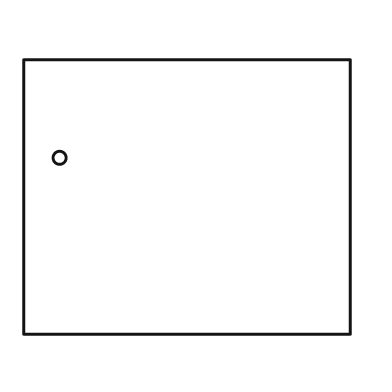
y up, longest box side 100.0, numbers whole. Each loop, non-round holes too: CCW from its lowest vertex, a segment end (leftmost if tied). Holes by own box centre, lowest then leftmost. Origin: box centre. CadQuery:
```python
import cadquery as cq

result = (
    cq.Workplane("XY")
    .moveTo(-50.0, -42.0)
    .lineTo(50.0, -42.0)
    .lineTo(50.0, 42.0)
    .lineTo(-50.0, 42.0)
    .close()
    .moveTo(-39.0, 12.0)
    .circle(2.0)
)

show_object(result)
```